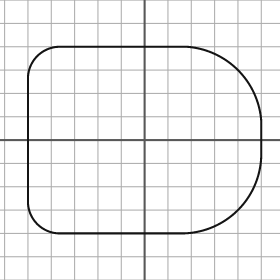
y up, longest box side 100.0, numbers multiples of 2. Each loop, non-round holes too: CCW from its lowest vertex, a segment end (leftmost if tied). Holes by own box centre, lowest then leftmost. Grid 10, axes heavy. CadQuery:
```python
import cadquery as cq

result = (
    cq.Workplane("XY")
    .moveTo(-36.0, -40.0)
    .lineTo(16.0, -40.0)
    .threePointArc((40.0, -30.0), (50.0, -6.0))
    .lineTo(50.0, 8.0)
    .threePointArc((40.0, 30.0), (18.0, 40.0))
    .lineTo(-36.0, 40.0)
    .threePointArc((-46.0, 36.0), (-50.0, 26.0))
    .lineTo(-50.0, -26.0)
    .threePointArc((-46.0, -36.0), (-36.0, -40.0))
    .close()
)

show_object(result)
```